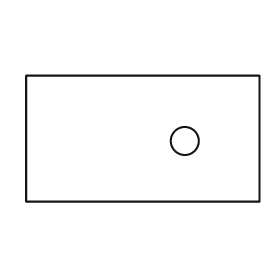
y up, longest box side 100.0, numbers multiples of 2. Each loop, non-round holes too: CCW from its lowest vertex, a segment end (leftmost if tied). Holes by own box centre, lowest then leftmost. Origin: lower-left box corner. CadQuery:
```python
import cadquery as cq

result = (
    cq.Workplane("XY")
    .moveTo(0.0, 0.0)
    .lineTo(100.0, 0.0)
    .lineTo(100.0, 54.0)
    .lineTo(0.0, 54.0)
    .close()
    .moveTo(68.0, 26.0)
    .circle(6.0)
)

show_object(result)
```